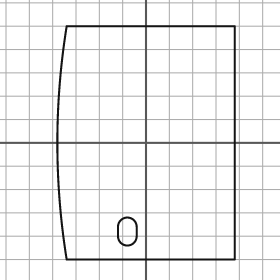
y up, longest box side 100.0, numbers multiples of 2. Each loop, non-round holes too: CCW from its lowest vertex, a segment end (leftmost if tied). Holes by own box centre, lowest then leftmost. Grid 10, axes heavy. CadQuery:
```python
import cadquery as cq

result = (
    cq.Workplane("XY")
    .moveTo(-34.0, -50.0)
    .lineTo(38.0, -50.0)
    .lineTo(38.0, 50.0)
    .lineTo(-34.0, 50.0)
    .threePointArc((-38.0, 0.0), (-34.0, -50.0))
    .close()
    .moveTo(-12.0, -40.0)
    .threePointArc((-8.0, -44.0), (-4.0, -40.0))
    .lineTo(-4.0, -36.0)
    .threePointArc((-8.0, -32.0), (-12.0, -36.0))
    .close()
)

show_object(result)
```